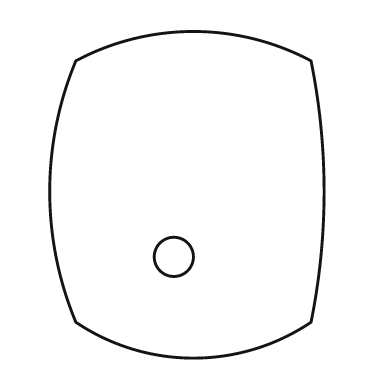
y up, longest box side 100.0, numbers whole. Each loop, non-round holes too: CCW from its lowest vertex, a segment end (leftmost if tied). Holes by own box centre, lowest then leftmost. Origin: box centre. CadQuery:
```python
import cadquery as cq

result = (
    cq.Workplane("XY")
    .moveTo(-34.0, -39.0)
    .threePointArc((2.0, -50.0), (38.0, -39.0))
    .threePointArc((42.0, 1.0), (38.0, 41.0))
    .threePointArc((2.0, 50.0), (-34.0, 41.0))
    .threePointArc((-42.0, 1.0), (-34.0, -39.0))
    .close()
    .moveTo(-4.0, -19.0)
    .circle(6.0)
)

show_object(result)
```